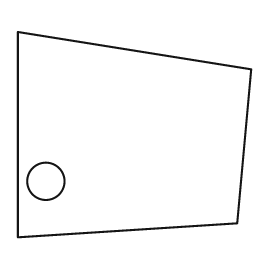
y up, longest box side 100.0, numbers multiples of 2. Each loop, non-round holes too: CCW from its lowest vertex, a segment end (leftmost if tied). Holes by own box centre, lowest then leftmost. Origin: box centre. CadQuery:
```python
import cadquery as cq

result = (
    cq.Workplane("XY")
    .moveTo(-50.0, -44.0)
    .lineTo(44.0, -38.0)
    .lineTo(50.0, 28.0)
    .lineTo(-50.0, 44.0)
    .close()
    .moveTo(-38.0, -20.0)
    .circle(8.0)
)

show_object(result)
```